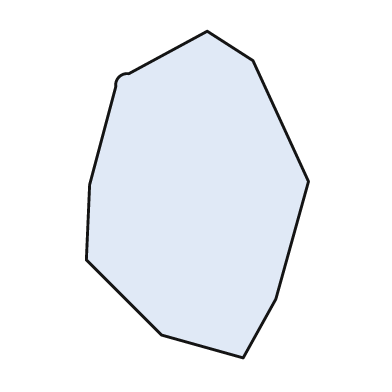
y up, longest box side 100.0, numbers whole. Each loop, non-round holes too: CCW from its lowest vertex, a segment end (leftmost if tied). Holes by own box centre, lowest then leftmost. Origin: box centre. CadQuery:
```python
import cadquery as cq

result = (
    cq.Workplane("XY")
    .moveTo(14.0, -50.0)
    .lineTo(24.0, -32.0)
    .lineTo(34.0, 4.0)
    .lineTo(17.0, 41.0)
    .lineTo(3.0, 50.0)
    .lineTo(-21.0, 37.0)
    .threePointArc((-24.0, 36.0), (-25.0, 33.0))
    .lineTo(-33.0, 3.0)
    .lineTo(-34.0, -20.0)
    .lineTo(-11.0, -43.0)
    .close()
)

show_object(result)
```